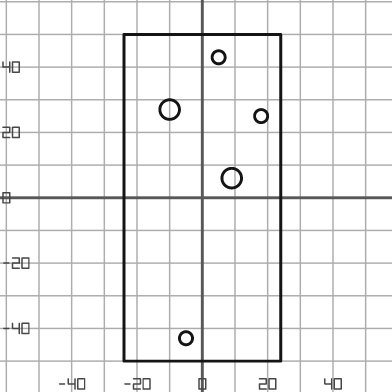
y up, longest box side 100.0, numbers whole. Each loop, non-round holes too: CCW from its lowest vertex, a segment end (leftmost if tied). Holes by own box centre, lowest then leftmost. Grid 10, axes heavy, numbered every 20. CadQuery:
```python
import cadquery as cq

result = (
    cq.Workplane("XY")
    .moveTo(-24.0, -50.0)
    .lineTo(24.0, -50.0)
    .lineTo(24.0, 50.0)
    .lineTo(-24.0, 50.0)
    .close()
    .moveTo(-5.0, -43.0)
    .circle(2.0)
    .moveTo(9.0, 6.0)
    .circle(3.0)
    .moveTo(18.0, 25.0)
    .circle(2.0)
    .moveTo(-10.0, 27.0)
    .circle(3.0)
    .moveTo(5.0, 43.0)
    .circle(2.0)
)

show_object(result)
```